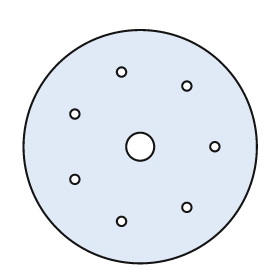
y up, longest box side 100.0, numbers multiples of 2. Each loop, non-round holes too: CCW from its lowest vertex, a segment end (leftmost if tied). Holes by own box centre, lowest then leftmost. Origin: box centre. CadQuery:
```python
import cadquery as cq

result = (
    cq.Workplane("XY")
    .moveTo(0.0, 0.0)
    .circle(50.0)
    .moveTo(-8.0, -32.0)
    .circle(2.0)
    .moveTo(20.0, -26.0)
    .circle(2.0)
    .moveTo(-28.0, -14.0)
    .circle(2.0)
    .moveTo(0.0, 0.0)
    .circle(6.0)
    .moveTo(32.0, 0.0)
    .circle(2.0)
    .moveTo(-28.0, 14.0)
    .circle(2.0)
    .moveTo(20.0, 26.0)
    .circle(2.0)
    .moveTo(-8.0, 32.0)
    .circle(2.0)
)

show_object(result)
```